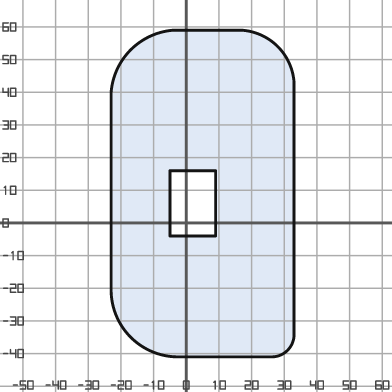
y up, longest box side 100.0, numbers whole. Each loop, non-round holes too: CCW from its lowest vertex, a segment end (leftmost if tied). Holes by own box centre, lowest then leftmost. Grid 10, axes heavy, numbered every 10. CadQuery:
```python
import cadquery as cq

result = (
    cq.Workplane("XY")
    .moveTo(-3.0, -41.0)
    .lineTo(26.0, -41.0)
    .threePointArc((31.0, -39.0), (33.0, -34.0))
    .lineTo(33.0, 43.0)
    .threePointArc((28.0, 54.0), (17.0, 59.0))
    .lineTo(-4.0, 59.0)
    .threePointArc((-17.0, 53.0), (-23.0, 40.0))
    .lineTo(-23.0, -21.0)
    .threePointArc((-17.0, -35.0), (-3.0, -41.0))
    .close()
    .moveTo(-5.0, -4.0)
    .lineTo(9.0, -4.0)
    .lineTo(9.0, 16.0)
    .lineTo(-5.0, 16.0)
    .close()
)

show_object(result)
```